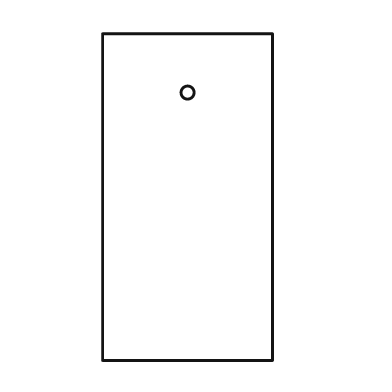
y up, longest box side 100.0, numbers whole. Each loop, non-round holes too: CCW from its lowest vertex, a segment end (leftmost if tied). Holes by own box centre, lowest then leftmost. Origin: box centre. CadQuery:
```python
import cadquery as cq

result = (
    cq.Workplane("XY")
    .moveTo(-26.0, -50.0)
    .lineTo(26.0, -50.0)
    .lineTo(26.0, 50.0)
    .lineTo(-26.0, 50.0)
    .close()
    .moveTo(0.0, 32.0)
    .circle(2.0)
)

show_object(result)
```